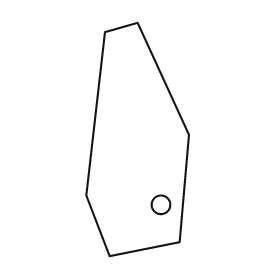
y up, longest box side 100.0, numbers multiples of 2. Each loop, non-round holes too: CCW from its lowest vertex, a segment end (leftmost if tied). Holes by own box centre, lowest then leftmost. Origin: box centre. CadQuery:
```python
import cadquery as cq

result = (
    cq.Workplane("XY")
    .moveTo(-12.0, -50.0)
    .lineTo(18.0, -44.0)
    .lineTo(22.0, 2.0)
    .lineTo(0.0, 50.0)
    .lineTo(-14.0, 46.0)
    .lineTo(-22.0, -24.0)
    .close()
    .moveTo(10.0, -28.0)
    .circle(4.0)
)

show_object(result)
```